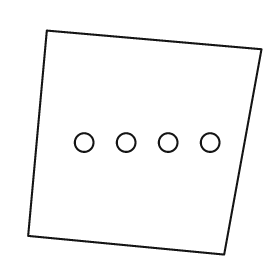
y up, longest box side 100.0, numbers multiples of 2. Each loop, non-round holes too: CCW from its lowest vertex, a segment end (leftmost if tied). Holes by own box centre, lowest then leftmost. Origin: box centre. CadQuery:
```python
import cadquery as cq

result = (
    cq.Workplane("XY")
    .moveTo(34.0, -48.0)
    .lineTo(50.0, 40.0)
    .lineTo(-42.0, 48.0)
    .lineTo(-50.0, -40.0)
    .close()
    .moveTo(-26.0, 0.0)
    .circle(4.0)
    .moveTo(-8.0, 0.0)
    .circle(4.0)
    .moveTo(10.0, 0.0)
    .circle(4.0)
    .moveTo(28.0, 0.0)
    .circle(4.0)
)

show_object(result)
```